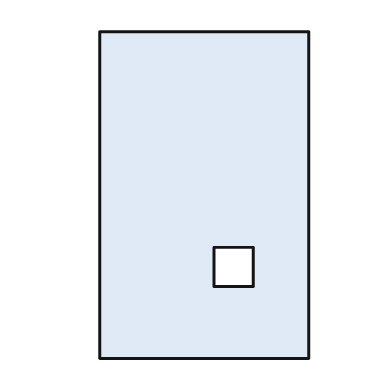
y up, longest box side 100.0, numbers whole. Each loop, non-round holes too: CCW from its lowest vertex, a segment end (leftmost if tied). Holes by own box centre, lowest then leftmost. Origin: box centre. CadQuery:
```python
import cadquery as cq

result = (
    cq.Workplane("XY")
    .moveTo(-32.0, -50.0)
    .lineTo(32.0, -50.0)
    .lineTo(32.0, 50.0)
    .lineTo(-32.0, 50.0)
    .close()
    .moveTo(3.0, -28.0)
    .lineTo(15.0, -28.0)
    .lineTo(15.0, -16.0)
    .lineTo(3.0, -16.0)
    .close()
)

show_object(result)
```